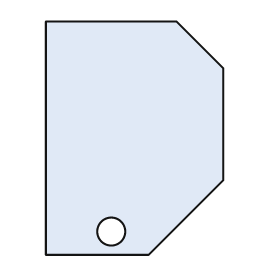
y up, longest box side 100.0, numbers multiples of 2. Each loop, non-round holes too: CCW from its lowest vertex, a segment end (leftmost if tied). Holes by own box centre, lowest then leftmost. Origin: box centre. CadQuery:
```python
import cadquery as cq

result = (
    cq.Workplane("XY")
    .moveTo(-38.0, -50.0)
    .lineTo(6.0, -50.0)
    .lineTo(38.0, -18.0)
    .lineTo(38.0, 30.0)
    .lineTo(18.0, 50.0)
    .lineTo(-38.0, 50.0)
    .close()
    .moveTo(-10.0, -40.0)
    .circle(6.0)
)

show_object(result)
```